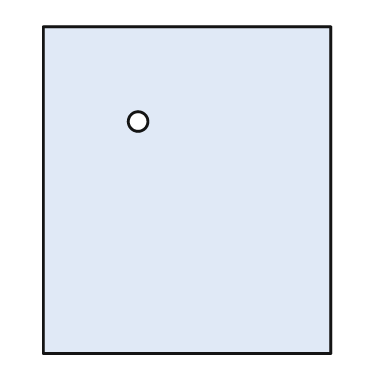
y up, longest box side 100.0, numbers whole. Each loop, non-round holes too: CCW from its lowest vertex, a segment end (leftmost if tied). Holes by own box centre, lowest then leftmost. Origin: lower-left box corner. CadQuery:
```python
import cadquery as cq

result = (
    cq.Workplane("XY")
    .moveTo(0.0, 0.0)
    .lineTo(88.0, 0.0)
    .lineTo(88.0, 100.0)
    .lineTo(0.0, 100.0)
    .close()
    .moveTo(29.0, 71.0)
    .circle(3.0)
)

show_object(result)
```